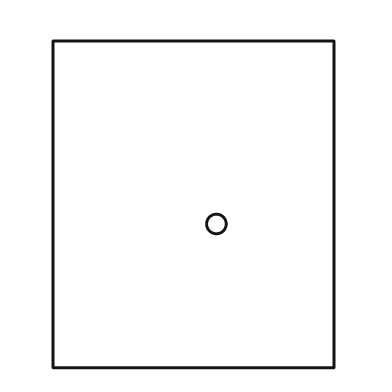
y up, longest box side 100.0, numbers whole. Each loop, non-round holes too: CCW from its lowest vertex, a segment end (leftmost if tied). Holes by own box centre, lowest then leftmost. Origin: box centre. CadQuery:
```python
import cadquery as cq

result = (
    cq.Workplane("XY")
    .moveTo(-43.0, -50.0)
    .lineTo(43.0, -50.0)
    .lineTo(43.0, 50.0)
    .lineTo(-43.0, 50.0)
    .close()
    .moveTo(7.0, -6.0)
    .circle(3.0)
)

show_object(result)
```